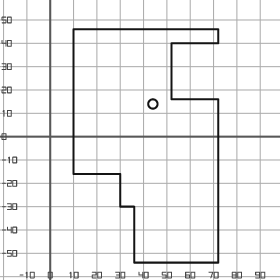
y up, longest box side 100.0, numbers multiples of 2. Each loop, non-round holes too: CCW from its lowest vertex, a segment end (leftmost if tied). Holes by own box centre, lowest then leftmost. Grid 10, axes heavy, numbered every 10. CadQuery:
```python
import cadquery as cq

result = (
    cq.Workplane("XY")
    .moveTo(36.0, -54.0)
    .lineTo(72.0, -54.0)
    .lineTo(72.0, 16.0)
    .lineTo(52.0, 16.0)
    .lineTo(52.0, 40.0)
    .lineTo(72.0, 40.0)
    .lineTo(72.0, 46.0)
    .lineTo(10.0, 46.0)
    .lineTo(10.0, -16.0)
    .lineTo(30.0, -16.0)
    .lineTo(30.0, -30.0)
    .lineTo(36.0, -30.0)
    .close()
    .moveTo(44.0, 14.0)
    .circle(2.0)
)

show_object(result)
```